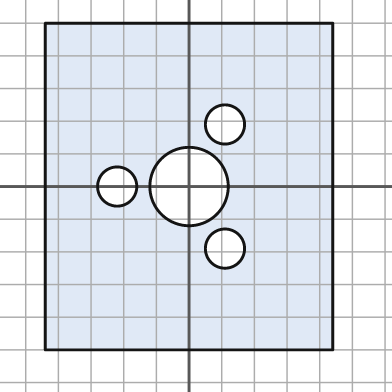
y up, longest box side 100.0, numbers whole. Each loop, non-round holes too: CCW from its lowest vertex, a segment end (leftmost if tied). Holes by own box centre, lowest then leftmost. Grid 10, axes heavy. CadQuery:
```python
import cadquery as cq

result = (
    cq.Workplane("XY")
    .moveTo(-44.0, -50.0)
    .lineTo(44.0, -50.0)
    .lineTo(44.0, 50.0)
    .lineTo(-44.0, 50.0)
    .close()
    .moveTo(11.0, -19.0)
    .circle(6.0)
    .moveTo(-22.0, 0.0)
    .circle(6.0)
    .moveTo(0.0, 0.0)
    .circle(12.0)
    .moveTo(11.0, 19.0)
    .circle(6.0)
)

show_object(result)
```